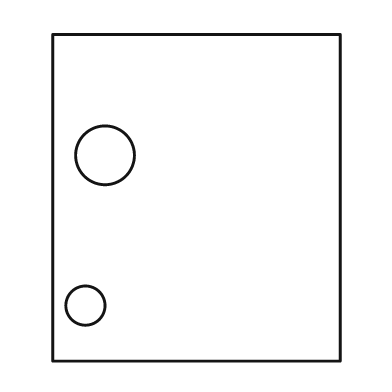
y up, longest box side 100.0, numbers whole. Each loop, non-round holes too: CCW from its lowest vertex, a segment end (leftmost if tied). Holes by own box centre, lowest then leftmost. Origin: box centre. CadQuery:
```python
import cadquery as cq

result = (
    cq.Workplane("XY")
    .moveTo(-44.0, -50.0)
    .lineTo(44.0, -50.0)
    .lineTo(44.0, 50.0)
    .lineTo(-44.0, 50.0)
    .close()
    .moveTo(-34.0, -33.0)
    .circle(6.0)
    .moveTo(-28.0, 13.0)
    .circle(9.0)
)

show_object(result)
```